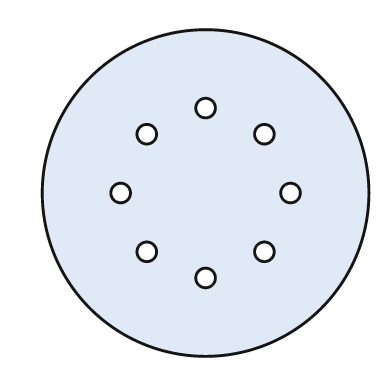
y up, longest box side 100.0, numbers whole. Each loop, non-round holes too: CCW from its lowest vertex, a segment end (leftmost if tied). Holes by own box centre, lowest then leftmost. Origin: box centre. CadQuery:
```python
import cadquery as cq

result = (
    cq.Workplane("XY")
    .moveTo(0.0, 0.0)
    .circle(50.0)
    .moveTo(0.0, -26.0)
    .circle(3.0)
    .moveTo(-18.0, -18.0)
    .circle(3.0)
    .moveTo(18.0, -18.0)
    .circle(3.0)
    .moveTo(-26.0, 0.0)
    .circle(3.0)
    .moveTo(26.0, 0.0)
    .circle(3.0)
    .moveTo(-18.0, 18.0)
    .circle(3.0)
    .moveTo(18.0, 18.0)
    .circle(3.0)
    .moveTo(0.0, 26.0)
    .circle(3.0)
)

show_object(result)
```